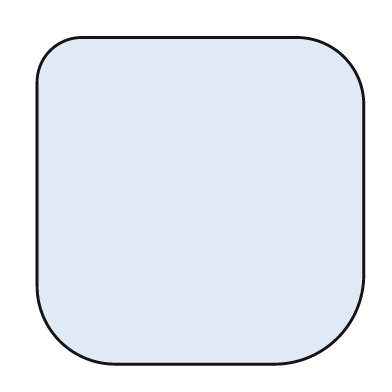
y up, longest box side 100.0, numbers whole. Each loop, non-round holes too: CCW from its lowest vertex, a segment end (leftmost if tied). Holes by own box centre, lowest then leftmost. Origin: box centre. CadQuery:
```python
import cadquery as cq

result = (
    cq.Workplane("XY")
    .moveTo(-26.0, -50.0)
    .lineTo(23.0, -50.0)
    .threePointArc((42.0, -42.0), (50.0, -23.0))
    .lineTo(50.0, 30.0)
    .threePointArc((44.0, 44.0), (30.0, 50.0))
    .lineTo(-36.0, 50.0)
    .threePointArc((-46.0, 46.0), (-50.0, 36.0))
    .lineTo(-50.0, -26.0)
    .threePointArc((-43.0, -43.0), (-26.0, -50.0))
    .close()
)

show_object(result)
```